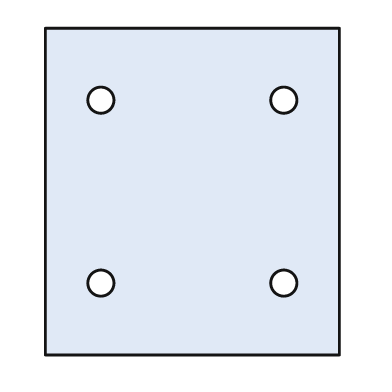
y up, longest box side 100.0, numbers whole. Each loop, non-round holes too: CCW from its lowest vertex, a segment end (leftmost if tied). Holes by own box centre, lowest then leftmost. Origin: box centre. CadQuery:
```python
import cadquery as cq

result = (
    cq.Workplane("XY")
    .moveTo(-45.0, -50.0)
    .lineTo(45.0, -50.0)
    .lineTo(45.0, 50.0)
    .lineTo(-45.0, 50.0)
    .close()
    .moveTo(-28.0, -28.0)
    .circle(4.0)
    .moveTo(28.0, -28.0)
    .circle(4.0)
    .moveTo(-28.0, 28.0)
    .circle(4.0)
    .moveTo(28.0, 28.0)
    .circle(4.0)
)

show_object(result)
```